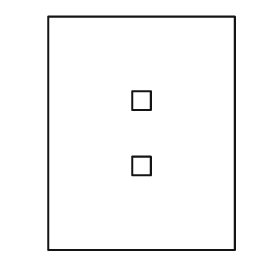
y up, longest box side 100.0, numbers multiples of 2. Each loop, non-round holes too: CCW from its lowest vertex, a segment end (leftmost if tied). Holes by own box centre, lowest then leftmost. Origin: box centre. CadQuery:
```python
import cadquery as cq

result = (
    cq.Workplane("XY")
    .moveTo(-40.0, -50.0)
    .lineTo(40.0, -50.0)
    .lineTo(40.0, 50.0)
    .lineTo(-40.0, 50.0)
    .close()
    .moveTo(-4.0, -18.0)
    .lineTo(4.0, -18.0)
    .lineTo(4.0, -10.0)
    .lineTo(-4.0, -10.0)
    .close()
    .moveTo(-4.0, 10.0)
    .lineTo(4.0, 10.0)
    .lineTo(4.0, 18.0)
    .lineTo(-4.0, 18.0)
    .close()
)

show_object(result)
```